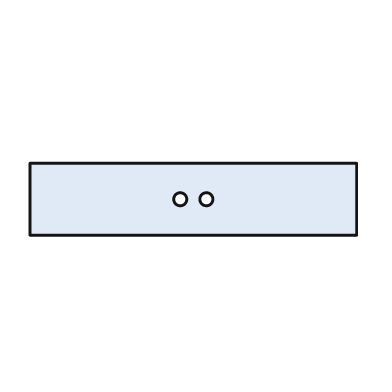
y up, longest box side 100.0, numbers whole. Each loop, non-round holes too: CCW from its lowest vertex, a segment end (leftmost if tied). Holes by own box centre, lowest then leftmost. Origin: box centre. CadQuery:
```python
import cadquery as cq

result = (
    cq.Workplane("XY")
    .moveTo(-50.0, -11.0)
    .lineTo(50.0, -11.0)
    .lineTo(50.0, 11.0)
    .lineTo(-50.0, 11.0)
    .close()
    .moveTo(-4.0, 0.0)
    .circle(2.0)
    .moveTo(4.0, 0.0)
    .circle(2.0)
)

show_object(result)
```